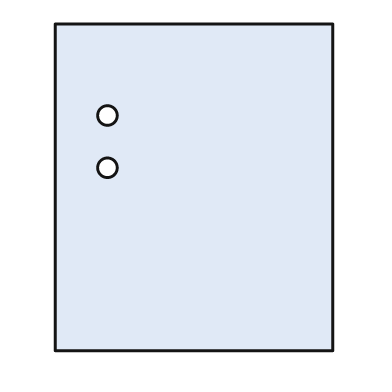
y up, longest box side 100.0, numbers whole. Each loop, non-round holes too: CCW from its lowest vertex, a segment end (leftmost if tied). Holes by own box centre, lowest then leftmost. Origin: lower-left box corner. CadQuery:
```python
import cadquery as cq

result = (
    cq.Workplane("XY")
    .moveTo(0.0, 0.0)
    .lineTo(85.0, 0.0)
    .lineTo(85.0, 100.0)
    .lineTo(0.0, 100.0)
    .close()
    .moveTo(16.0, 56.0)
    .circle(3.0)
    .moveTo(16.0, 72.0)
    .circle(3.0)
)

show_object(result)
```